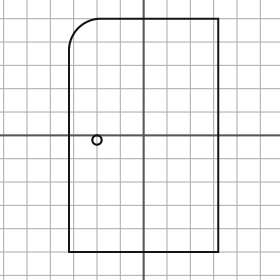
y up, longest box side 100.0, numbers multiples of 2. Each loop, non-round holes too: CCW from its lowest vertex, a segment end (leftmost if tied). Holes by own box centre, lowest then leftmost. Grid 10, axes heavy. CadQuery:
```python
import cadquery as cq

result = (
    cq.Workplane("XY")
    .moveTo(-32.0, -50.0)
    .lineTo(32.0, -50.0)
    .lineTo(32.0, 50.0)
    .lineTo(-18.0, 50.0)
    .threePointArc((-28.0, 46.0), (-32.0, 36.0))
    .close()
    .moveTo(-20.0, -2.0)
    .circle(2.0)
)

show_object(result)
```